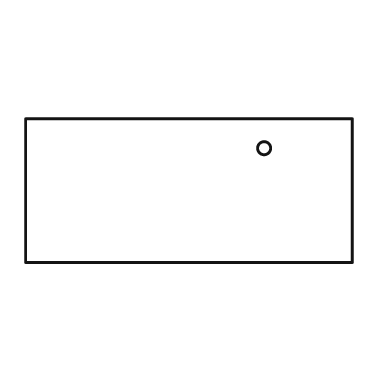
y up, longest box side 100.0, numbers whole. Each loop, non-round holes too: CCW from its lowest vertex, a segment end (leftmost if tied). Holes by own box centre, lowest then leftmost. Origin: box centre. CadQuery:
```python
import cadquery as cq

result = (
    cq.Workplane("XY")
    .moveTo(-50.0, -22.0)
    .lineTo(50.0, -22.0)
    .lineTo(50.0, 22.0)
    .lineTo(-50.0, 22.0)
    .close()
    .moveTo(23.0, 13.0)
    .circle(2.0)
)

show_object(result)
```